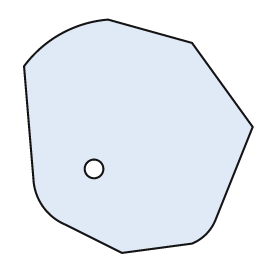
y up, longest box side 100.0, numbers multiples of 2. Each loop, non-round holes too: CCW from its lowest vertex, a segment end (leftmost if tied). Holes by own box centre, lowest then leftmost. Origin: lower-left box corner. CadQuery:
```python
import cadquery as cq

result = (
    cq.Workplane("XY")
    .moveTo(42.0, 0.0)
    .lineTo(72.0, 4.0)
    .threePointArc((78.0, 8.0), (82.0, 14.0))
    .lineTo(98.0, 54.0)
    .lineTo(72.0, 90.0)
    .lineTo(36.0, 100.0)
    .threePointArc((16.0, 94.0), (0.0, 80.0))
    .lineTo(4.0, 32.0)
    .threePointArc((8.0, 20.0), (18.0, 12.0))
    .close()
    .moveTo(30.0, 36.0)
    .circle(4.0)
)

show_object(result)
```